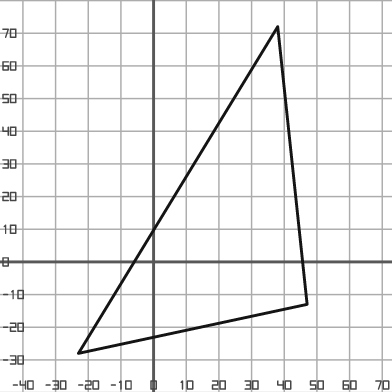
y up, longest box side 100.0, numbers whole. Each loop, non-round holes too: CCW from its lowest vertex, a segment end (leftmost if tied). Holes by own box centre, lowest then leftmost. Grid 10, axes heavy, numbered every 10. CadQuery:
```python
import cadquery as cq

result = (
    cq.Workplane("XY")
    .moveTo(-23.0, -28.0)
    .lineTo(47.0, -13.0)
    .lineTo(38.0, 72.0)
    .close()
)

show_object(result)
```